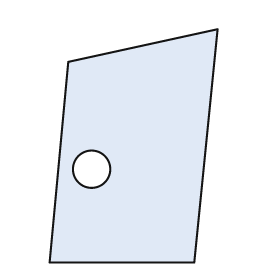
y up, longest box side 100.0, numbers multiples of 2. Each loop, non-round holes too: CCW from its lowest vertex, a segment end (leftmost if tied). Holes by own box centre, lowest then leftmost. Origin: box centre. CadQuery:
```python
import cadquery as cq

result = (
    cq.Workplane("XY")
    .moveTo(-36.0, -50.0)
    .lineTo(26.0, -50.0)
    .lineTo(36.0, 50.0)
    .lineTo(-28.0, 36.0)
    .close()
    .moveTo(-18.0, -10.0)
    .circle(8.0)
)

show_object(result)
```